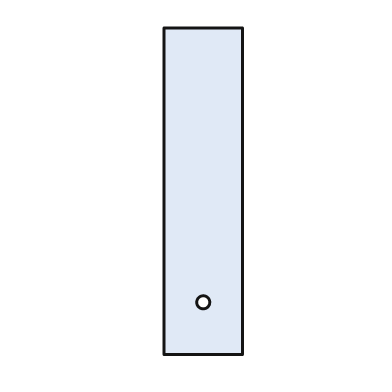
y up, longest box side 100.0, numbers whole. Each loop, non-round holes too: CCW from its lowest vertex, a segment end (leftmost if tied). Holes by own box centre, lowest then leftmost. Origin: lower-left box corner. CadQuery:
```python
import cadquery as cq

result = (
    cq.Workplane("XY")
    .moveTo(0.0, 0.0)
    .lineTo(24.0, 0.0)
    .lineTo(24.0, 100.0)
    .lineTo(0.0, 100.0)
    .close()
    .moveTo(12.0, 16.0)
    .circle(2.0)
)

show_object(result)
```